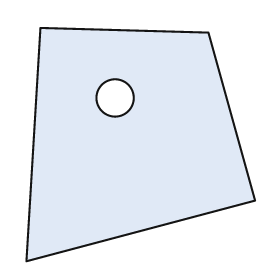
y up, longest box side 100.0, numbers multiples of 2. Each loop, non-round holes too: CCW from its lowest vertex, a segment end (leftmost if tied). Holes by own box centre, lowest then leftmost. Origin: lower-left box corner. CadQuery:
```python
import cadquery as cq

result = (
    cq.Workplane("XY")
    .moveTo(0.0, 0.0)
    .lineTo(98.0, 26.0)
    .lineTo(78.0, 98.0)
    .lineTo(6.0, 100.0)
    .close()
    .moveTo(38.0, 70.0)
    .circle(8.0)
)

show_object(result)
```